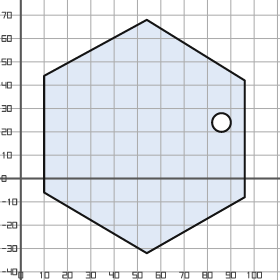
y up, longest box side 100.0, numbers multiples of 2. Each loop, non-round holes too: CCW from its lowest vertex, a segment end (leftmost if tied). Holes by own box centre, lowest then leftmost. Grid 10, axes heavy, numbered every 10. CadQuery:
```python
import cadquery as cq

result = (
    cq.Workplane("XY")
    .moveTo(54.0, -32.0)
    .lineTo(96.0, -8.0)
    .lineTo(96.0, 42.0)
    .lineTo(54.0, 68.0)
    .lineTo(10.0, 44.0)
    .lineTo(10.0, -6.0)
    .close()
    .moveTo(86.0, 24.0)
    .circle(4.0)
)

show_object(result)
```